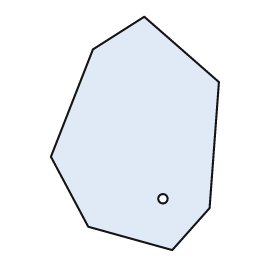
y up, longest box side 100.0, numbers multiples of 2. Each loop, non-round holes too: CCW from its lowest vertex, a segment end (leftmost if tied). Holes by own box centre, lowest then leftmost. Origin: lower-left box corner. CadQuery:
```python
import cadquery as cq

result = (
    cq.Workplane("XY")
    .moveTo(52.0, 0.0)
    .lineTo(68.0, 18.0)
    .lineTo(72.0, 72.0)
    .lineTo(40.0, 100.0)
    .lineTo(18.0, 86.0)
    .lineTo(0.0, 40.0)
    .lineTo(16.0, 10.0)
    .close()
    .moveTo(48.0, 22.0)
    .circle(2.0)
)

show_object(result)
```